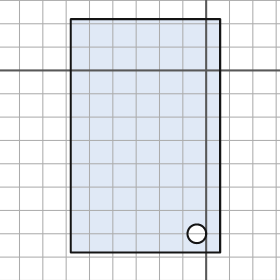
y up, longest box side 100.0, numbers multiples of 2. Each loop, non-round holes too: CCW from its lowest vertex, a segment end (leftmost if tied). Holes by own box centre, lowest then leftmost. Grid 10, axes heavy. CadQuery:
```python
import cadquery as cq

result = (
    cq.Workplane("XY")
    .moveTo(-58.0, -78.0)
    .lineTo(6.0, -78.0)
    .lineTo(6.0, 22.0)
    .lineTo(-58.0, 22.0)
    .close()
    .moveTo(-4.0, -70.0)
    .circle(4.0)
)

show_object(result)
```